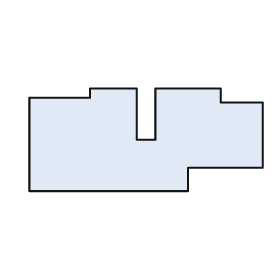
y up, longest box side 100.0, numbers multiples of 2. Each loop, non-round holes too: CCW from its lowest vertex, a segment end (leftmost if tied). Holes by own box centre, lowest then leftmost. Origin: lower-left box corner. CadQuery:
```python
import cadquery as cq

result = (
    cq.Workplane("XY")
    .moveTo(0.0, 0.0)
    .lineTo(68.0, 0.0)
    .lineTo(68.0, 10.0)
    .lineTo(100.0, 10.0)
    .lineTo(100.0, 38.0)
    .lineTo(82.0, 38.0)
    .lineTo(82.0, 44.0)
    .lineTo(54.0, 44.0)
    .lineTo(54.0, 22.0)
    .lineTo(46.0, 22.0)
    .lineTo(46.0, 44.0)
    .lineTo(26.0, 44.0)
    .lineTo(26.0, 40.0)
    .lineTo(0.0, 40.0)
    .close()
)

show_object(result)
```